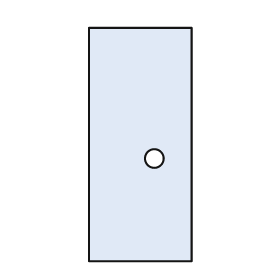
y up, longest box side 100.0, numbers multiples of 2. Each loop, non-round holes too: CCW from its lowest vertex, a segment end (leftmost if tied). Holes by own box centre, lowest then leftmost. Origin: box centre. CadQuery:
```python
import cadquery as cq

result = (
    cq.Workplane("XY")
    .moveTo(-22.0, -50.0)
    .lineTo(22.0, -50.0)
    .lineTo(22.0, 50.0)
    .lineTo(-22.0, 50.0)
    .close()
    .moveTo(6.0, -6.0)
    .circle(4.0)
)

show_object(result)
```